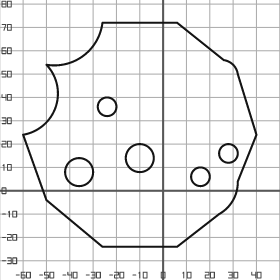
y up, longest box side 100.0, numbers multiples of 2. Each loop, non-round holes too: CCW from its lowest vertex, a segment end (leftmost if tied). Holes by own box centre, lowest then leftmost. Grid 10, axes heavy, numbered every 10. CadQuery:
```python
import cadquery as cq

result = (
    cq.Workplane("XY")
    .moveTo(-26.0, -24.0)
    .lineTo(6.0, -24.0)
    .lineTo(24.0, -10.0)
    .threePointArc((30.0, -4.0), (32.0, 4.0))
    .lineTo(40.0, 24.0)
    .lineTo(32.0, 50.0)
    .threePointArc((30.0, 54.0), (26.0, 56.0))
    .lineTo(6.0, 72.0)
    .lineTo(-26.0, 72.0)
    .threePointArc((-34.0, 58.0), (-50.0, 54.0))
    .threePointArc((-46.0, 36.0), (-60.0, 24.0))
    .lineTo(-50.0, -4.0)
    .close()
    .moveTo(16.0, 6.0)
    .circle(4.0)
    .moveTo(-36.0, 8.0)
    .circle(6.0)
    .moveTo(-10.0, 14.0)
    .circle(6.0)
    .moveTo(28.0, 16.0)
    .circle(4.0)
    .moveTo(-24.0, 36.0)
    .circle(4.0)
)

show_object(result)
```